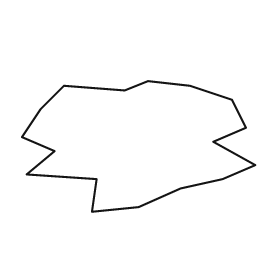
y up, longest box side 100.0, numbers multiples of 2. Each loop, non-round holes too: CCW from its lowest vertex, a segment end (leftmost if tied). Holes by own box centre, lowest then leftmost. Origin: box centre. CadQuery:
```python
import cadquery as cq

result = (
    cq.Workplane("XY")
    .moveTo(-20.0, -28.0)
    .lineTo(0.0, -26.0)
    .lineTo(18.0, -18.0)
    .lineTo(36.0, -14.0)
    .lineTo(50.0, -8.0)
    .lineTo(32.0, 2.0)
    .lineTo(46.0, 8.0)
    .lineTo(40.0, 20.0)
    .lineTo(22.0, 26.0)
    .lineTo(4.0, 28.0)
    .lineTo(-6.0, 24.0)
    .lineTo(-32.0, 26.0)
    .lineTo(-42.0, 16.0)
    .lineTo(-50.0, 4.0)
    .lineTo(-36.0, -2.0)
    .lineTo(-48.0, -12.0)
    .lineTo(-18.0, -14.0)
    .close()
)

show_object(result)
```